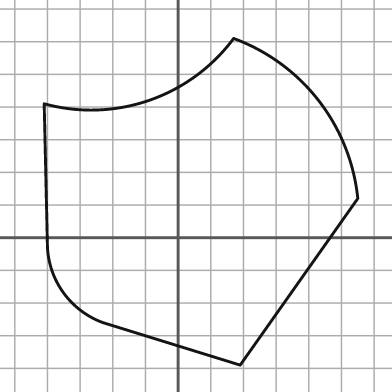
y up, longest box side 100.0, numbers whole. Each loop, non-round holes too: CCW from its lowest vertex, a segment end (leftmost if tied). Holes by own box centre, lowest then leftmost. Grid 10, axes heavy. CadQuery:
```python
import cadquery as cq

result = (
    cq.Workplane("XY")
    .moveTo(19.0, -39.0)
    .lineTo(55.0, 12.0)
    .threePointArc((43.0, 42.0), (17.0, 61.0))
    .threePointArc((-9.0, 42.0), (-41.0, 41.0))
    .lineTo(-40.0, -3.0)
    .threePointArc((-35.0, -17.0), (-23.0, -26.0))
    .close()
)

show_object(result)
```